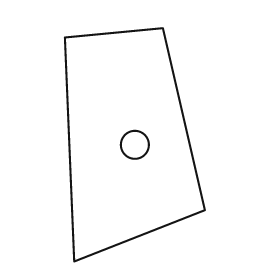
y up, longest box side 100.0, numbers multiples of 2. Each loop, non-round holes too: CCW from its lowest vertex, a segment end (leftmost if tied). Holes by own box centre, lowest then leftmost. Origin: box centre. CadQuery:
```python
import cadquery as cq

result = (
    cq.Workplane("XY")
    .moveTo(-26.0, -50.0)
    .lineTo(30.0, -28.0)
    .lineTo(12.0, 50.0)
    .lineTo(-30.0, 46.0)
    .close()
    .moveTo(0.0, 0.0)
    .circle(6.0)
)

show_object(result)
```